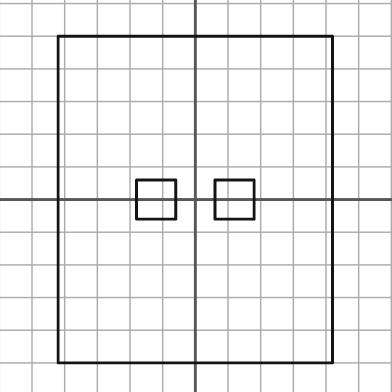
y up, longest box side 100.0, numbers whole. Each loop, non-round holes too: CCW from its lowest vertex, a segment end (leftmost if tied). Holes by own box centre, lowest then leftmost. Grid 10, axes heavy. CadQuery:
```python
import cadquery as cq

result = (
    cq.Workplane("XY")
    .moveTo(-42.0, -50.0)
    .lineTo(42.0, -50.0)
    .lineTo(42.0, 50.0)
    .lineTo(-42.0, 50.0)
    .close()
    .moveTo(-18.0, -6.0)
    .lineTo(-6.0, -6.0)
    .lineTo(-6.0, 6.0)
    .lineTo(-18.0, 6.0)
    .close()
    .moveTo(6.0, -6.0)
    .lineTo(18.0, -6.0)
    .lineTo(18.0, 6.0)
    .lineTo(6.0, 6.0)
    .close()
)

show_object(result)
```